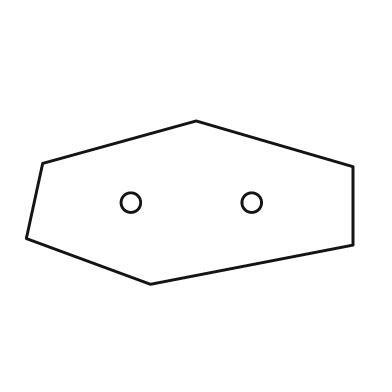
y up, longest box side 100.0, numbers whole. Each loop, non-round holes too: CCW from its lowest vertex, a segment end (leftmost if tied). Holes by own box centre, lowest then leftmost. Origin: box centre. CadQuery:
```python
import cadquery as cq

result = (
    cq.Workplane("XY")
    .moveTo(-12.0, -25.0)
    .lineTo(50.0, -13.0)
    .lineTo(50.0, 11.0)
    .lineTo(2.0, 25.0)
    .lineTo(-45.0, 12.0)
    .lineTo(-50.0, -11.0)
    .close()
    .moveTo(-18.0, 0.0)
    .circle(3.0)
    .moveTo(19.0, 0.0)
    .circle(3.0)
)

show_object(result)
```